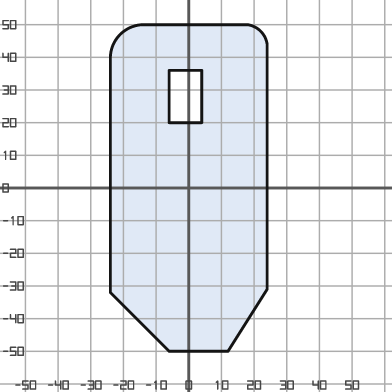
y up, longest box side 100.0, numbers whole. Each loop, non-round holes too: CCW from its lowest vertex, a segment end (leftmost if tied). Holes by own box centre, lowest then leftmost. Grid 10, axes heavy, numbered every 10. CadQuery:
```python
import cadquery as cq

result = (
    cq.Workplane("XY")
    .moveTo(-6.0, -50.0)
    .lineTo(12.0, -50.0)
    .lineTo(24.0, -31.0)
    .lineTo(24.0, 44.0)
    .threePointArc((22.0, 48.0), (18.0, 50.0))
    .lineTo(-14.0, 50.0)
    .threePointArc((-21.0, 47.0), (-24.0, 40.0))
    .lineTo(-24.0, -32.0)
    .close()
    .moveTo(-6.0, 20.0)
    .lineTo(4.0, 20.0)
    .lineTo(4.0, 36.0)
    .lineTo(-6.0, 36.0)
    .close()
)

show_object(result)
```